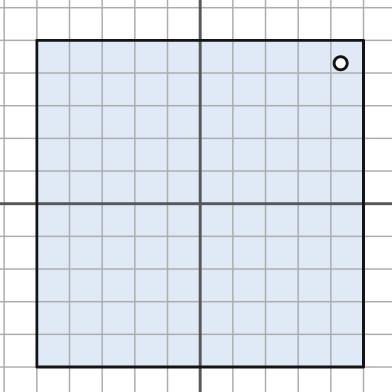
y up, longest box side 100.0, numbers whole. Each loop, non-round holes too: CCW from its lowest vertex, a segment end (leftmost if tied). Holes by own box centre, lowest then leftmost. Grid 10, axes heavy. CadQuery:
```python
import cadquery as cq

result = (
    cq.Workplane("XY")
    .moveTo(-50.0, -50.0)
    .lineTo(50.0, -50.0)
    .lineTo(50.0, 50.0)
    .lineTo(-50.0, 50.0)
    .close()
    .moveTo(43.0, 43.0)
    .circle(2.0)
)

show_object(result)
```